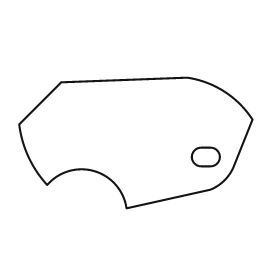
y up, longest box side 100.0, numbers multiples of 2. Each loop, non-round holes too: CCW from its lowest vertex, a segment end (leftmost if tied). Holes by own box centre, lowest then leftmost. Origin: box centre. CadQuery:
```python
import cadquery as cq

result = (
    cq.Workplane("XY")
    .moveTo(-4.0, -28.0)
    .lineTo(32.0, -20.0)
    .threePointArc((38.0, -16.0), (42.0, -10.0))
    .lineTo(50.0, 10.0)
    .threePointArc((38.0, 22.0), (22.0, 28.0))
    .lineTo(-32.0, 26.0)
    .lineTo(-50.0, 8.0)
    .threePointArc((-46.0, -6.0), (-38.0, -18.0))
    .threePointArc((-18.0, -12.0), (-4.0, -28.0))
    .close()
    .moveTo(28.0, -10.0)
    .lineTo(32.0, -10.0)
    .threePointArc((36.0, -6.0), (32.0, -2.0))
    .lineTo(28.0, -2.0)
    .threePointArc((24.0, -6.0), (28.0, -10.0))
    .close()
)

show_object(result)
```